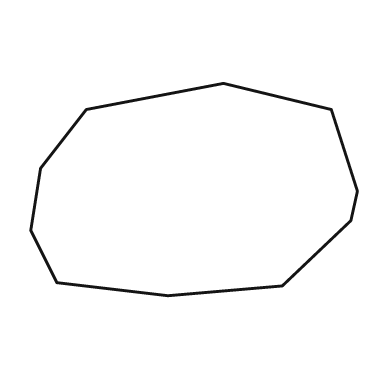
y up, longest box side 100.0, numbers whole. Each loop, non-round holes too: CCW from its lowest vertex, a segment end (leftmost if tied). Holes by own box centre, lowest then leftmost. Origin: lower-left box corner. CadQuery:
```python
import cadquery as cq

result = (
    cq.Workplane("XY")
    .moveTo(42.0, 0.0)
    .lineTo(77.0, 3.0)
    .lineTo(98.0, 23.0)
    .lineTo(100.0, 32.0)
    .lineTo(92.0, 57.0)
    .lineTo(59.0, 65.0)
    .lineTo(17.0, 57.0)
    .lineTo(3.0, 39.0)
    .lineTo(0.0, 20.0)
    .lineTo(8.0, 4.0)
    .close()
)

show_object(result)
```